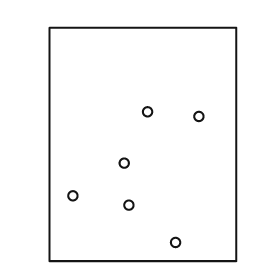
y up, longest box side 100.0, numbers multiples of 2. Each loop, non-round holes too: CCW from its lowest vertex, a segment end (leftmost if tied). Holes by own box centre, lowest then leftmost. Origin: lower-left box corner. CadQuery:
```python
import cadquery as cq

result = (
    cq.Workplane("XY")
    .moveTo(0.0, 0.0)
    .lineTo(80.0, 0.0)
    .lineTo(80.0, 100.0)
    .lineTo(0.0, 100.0)
    .close()
    .moveTo(54.0, 8.0)
    .circle(2.0)
    .moveTo(34.0, 24.0)
    .circle(2.0)
    .moveTo(10.0, 28.0)
    .circle(2.0)
    .moveTo(32.0, 42.0)
    .circle(2.0)
    .moveTo(64.0, 62.0)
    .circle(2.0)
    .moveTo(42.0, 64.0)
    .circle(2.0)
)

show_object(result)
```